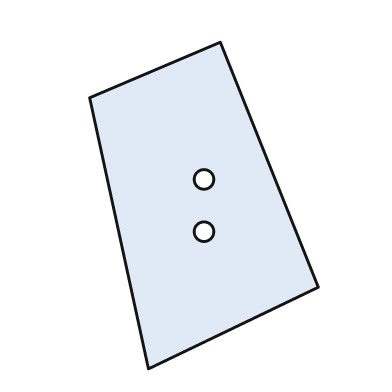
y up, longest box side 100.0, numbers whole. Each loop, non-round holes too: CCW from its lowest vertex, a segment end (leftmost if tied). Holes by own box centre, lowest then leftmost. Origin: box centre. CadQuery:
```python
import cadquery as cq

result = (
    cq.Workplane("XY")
    .moveTo(-17.0, -50.0)
    .lineTo(35.0, -25.0)
    .lineTo(5.0, 50.0)
    .lineTo(-35.0, 33.0)
    .close()
    .moveTo(0.0, -8.0)
    .circle(3.0)
    .moveTo(0.0, 8.0)
    .circle(3.0)
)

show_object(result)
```